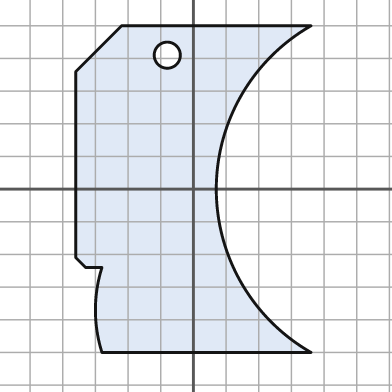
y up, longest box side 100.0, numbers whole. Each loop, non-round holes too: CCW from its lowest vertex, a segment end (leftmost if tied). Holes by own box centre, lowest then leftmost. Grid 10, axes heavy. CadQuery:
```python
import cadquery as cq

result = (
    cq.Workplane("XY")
    .moveTo(-28.0, -50.0)
    .lineTo(36.0, -50.0)
    .threePointArc((7.0, 0.0), (36.0, 50.0))
    .lineTo(-22.0, 50.0)
    .lineTo(-36.0, 36.0)
    .lineTo(-36.0, -21.0)
    .lineTo(-33.0, -24.0)
    .lineTo(-28.0, -24.0)
    .threePointArc((-30.0, -37.0), (-28.0, -50.0))
    .close()
    .moveTo(-8.0, 41.0)
    .circle(4.0)
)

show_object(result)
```